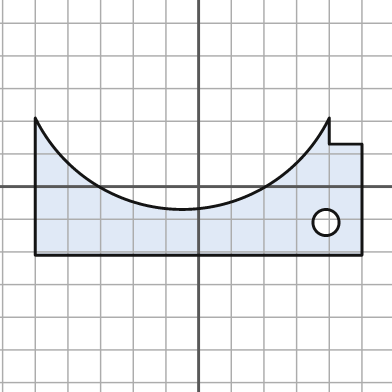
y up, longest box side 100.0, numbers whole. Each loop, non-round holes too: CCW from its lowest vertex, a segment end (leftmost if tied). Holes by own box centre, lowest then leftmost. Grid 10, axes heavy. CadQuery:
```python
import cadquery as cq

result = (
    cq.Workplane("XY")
    .moveTo(-50.0, -21.0)
    .lineTo(50.0, -21.0)
    .lineTo(50.0, 13.0)
    .lineTo(40.0, 13.0)
    .lineTo(40.0, 21.0)
    .threePointArc((-5.0, -7.0), (-50.0, 21.0))
    .close()
    .moveTo(39.0, -11.0)
    .circle(4.0)
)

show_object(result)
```